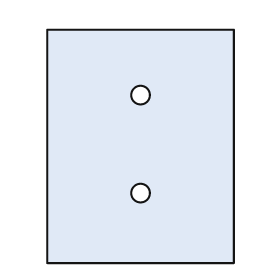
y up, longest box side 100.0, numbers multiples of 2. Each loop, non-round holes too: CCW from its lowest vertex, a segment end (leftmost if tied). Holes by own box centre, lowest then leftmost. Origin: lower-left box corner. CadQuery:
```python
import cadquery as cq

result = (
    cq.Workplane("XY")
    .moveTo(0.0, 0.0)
    .lineTo(80.0, 0.0)
    .lineTo(80.0, 100.0)
    .lineTo(0.0, 100.0)
    .close()
    .moveTo(40.0, 30.0)
    .circle(4.0)
    .moveTo(40.0, 72.0)
    .circle(4.0)
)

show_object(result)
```